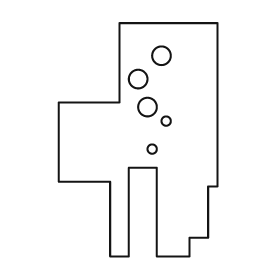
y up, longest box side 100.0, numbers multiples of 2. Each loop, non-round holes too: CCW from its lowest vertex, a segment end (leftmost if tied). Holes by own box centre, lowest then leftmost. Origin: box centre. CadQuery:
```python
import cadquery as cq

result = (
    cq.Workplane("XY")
    .moveTo(-12.0, -50.0)
    .lineTo(-4.0, -50.0)
    .lineTo(-4.0, -12.0)
    .lineTo(8.0, -12.0)
    .lineTo(8.0, -50.0)
    .lineTo(22.0, -50.0)
    .lineTo(22.0, -42.0)
    .lineTo(30.0, -42.0)
    .lineTo(30.0, -20.0)
    .lineTo(34.0, -20.0)
    .lineTo(34.0, 50.0)
    .lineTo(-8.0, 50.0)
    .lineTo(-8.0, 16.0)
    .lineTo(-34.0, 16.0)
    .lineTo(-34.0, -18.0)
    .lineTo(-12.0, -18.0)
    .close()
    .moveTo(6.0, -4.0)
    .circle(2.0)
    .moveTo(12.0, 8.0)
    .circle(2.0)
    .moveTo(4.0, 14.0)
    .circle(4.0)
    .moveTo(0.0, 26.0)
    .circle(4.0)
    .moveTo(10.0, 36.0)
    .circle(4.0)
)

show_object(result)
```